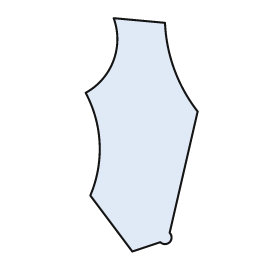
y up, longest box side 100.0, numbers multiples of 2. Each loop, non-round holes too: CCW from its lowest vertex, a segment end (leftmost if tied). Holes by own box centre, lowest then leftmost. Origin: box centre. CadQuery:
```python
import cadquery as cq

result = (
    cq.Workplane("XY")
    .moveTo(-4.0, -50.0)
    .lineTo(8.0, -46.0)
    .threePointArc((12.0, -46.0), (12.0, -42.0))
    .lineTo(24.0, 10.0)
    .threePointArc((14.0, 28.0), (10.0, 48.0))
    .lineTo(-12.0, 50.0)
    .threePointArc((-12.0, 32.0), (-24.0, 18.0))
    .threePointArc((-18.0, -4.0), (-22.0, -26.0))
    .close()
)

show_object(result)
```